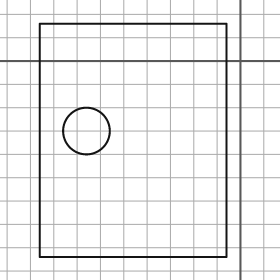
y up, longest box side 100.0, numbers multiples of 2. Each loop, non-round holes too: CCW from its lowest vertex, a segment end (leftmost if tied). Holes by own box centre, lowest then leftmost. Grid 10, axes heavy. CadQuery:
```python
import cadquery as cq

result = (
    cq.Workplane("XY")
    .moveTo(-86.0, -84.0)
    .lineTo(-6.0, -84.0)
    .lineTo(-6.0, 16.0)
    .lineTo(-86.0, 16.0)
    .close()
    .moveTo(-66.0, -30.0)
    .circle(10.0)
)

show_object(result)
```